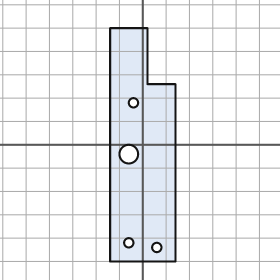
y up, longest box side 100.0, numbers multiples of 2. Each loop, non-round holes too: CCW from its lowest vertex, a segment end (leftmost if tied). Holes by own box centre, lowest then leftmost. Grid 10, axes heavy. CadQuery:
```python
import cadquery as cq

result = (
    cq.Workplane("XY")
    .moveTo(-14.0, -50.0)
    .lineTo(14.0, -50.0)
    .lineTo(14.0, 26.0)
    .lineTo(2.0, 26.0)
    .lineTo(2.0, 50.0)
    .lineTo(-14.0, 50.0)
    .close()
    .moveTo(6.0, -44.0)
    .circle(2.0)
    .moveTo(-6.0, -42.0)
    .circle(2.0)
    .moveTo(-6.0, -4.0)
    .circle(4.0)
    .moveTo(-4.0, 18.0)
    .circle(2.0)
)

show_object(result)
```